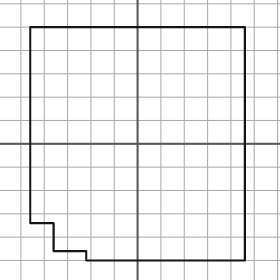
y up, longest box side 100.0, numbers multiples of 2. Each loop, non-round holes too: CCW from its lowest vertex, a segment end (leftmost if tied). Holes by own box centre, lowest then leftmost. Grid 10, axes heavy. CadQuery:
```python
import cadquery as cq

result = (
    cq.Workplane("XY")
    .moveTo(-22.0, -50.0)
    .lineTo(46.0, -50.0)
    .lineTo(46.0, 50.0)
    .lineTo(-46.0, 50.0)
    .lineTo(-46.0, -34.0)
    .lineTo(-36.0, -34.0)
    .lineTo(-36.0, -46.0)
    .lineTo(-22.0, -46.0)
    .close()
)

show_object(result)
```